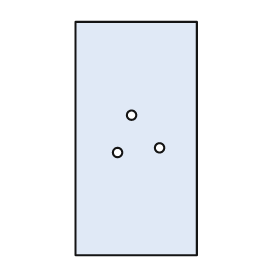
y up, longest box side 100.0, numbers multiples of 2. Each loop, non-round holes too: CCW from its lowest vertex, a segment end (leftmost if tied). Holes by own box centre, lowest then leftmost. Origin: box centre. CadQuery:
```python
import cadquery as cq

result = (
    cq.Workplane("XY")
    .moveTo(-26.0, -50.0)
    .lineTo(26.0, -50.0)
    .lineTo(26.0, 50.0)
    .lineTo(-26.0, 50.0)
    .close()
    .moveTo(-8.0, -6.0)
    .circle(2.0)
    .moveTo(10.0, -4.0)
    .circle(2.0)
    .moveTo(-2.0, 10.0)
    .circle(2.0)
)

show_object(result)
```